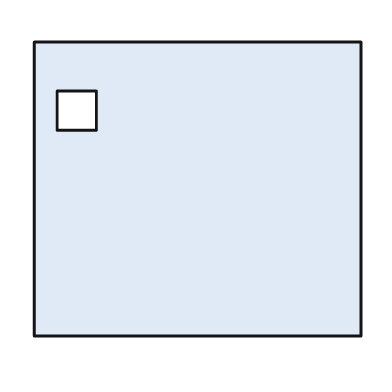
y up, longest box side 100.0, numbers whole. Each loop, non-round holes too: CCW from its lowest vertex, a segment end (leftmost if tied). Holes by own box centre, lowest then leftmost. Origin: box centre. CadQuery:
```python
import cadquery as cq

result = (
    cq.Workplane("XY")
    .moveTo(-50.0, -45.0)
    .lineTo(50.0, -45.0)
    .lineTo(50.0, 45.0)
    .lineTo(-50.0, 45.0)
    .close()
    .moveTo(-43.0, 18.0)
    .lineTo(-31.0, 18.0)
    .lineTo(-31.0, 30.0)
    .lineTo(-43.0, 30.0)
    .close()
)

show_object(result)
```